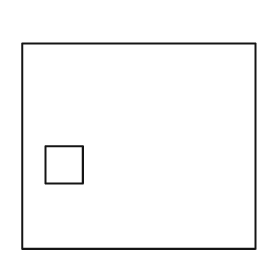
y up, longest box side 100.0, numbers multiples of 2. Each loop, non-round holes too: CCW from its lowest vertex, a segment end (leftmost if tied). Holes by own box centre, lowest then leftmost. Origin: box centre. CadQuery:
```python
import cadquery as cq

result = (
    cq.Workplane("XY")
    .moveTo(-50.0, -44.0)
    .lineTo(50.0, -44.0)
    .lineTo(50.0, 44.0)
    .lineTo(-50.0, 44.0)
    .close()
    .moveTo(-40.0, -16.0)
    .lineTo(-24.0, -16.0)
    .lineTo(-24.0, 0.0)
    .lineTo(-40.0, 0.0)
    .close()
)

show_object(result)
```